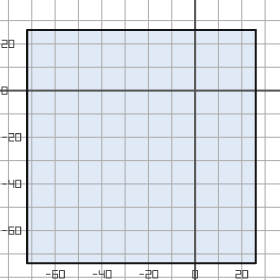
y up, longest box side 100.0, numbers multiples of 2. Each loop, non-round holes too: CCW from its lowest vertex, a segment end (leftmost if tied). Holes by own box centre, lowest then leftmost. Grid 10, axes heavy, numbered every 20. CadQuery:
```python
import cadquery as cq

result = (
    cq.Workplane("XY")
    .moveTo(-72.0, -74.0)
    .lineTo(26.0, -74.0)
    .lineTo(26.0, 26.0)
    .lineTo(-72.0, 26.0)
    .close()
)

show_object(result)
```